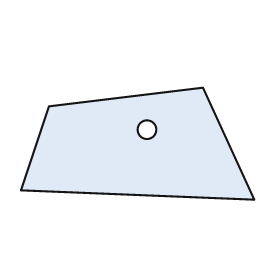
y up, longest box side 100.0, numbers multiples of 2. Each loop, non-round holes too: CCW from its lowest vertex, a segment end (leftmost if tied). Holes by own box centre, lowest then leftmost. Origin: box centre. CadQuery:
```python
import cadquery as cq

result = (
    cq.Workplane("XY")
    .moveTo(50.0, -24.0)
    .lineTo(28.0, 24.0)
    .lineTo(-38.0, 16.0)
    .lineTo(-50.0, -20.0)
    .close()
    .moveTo(4.0, 6.0)
    .circle(4.0)
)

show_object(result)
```